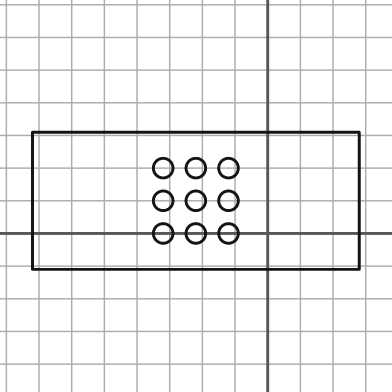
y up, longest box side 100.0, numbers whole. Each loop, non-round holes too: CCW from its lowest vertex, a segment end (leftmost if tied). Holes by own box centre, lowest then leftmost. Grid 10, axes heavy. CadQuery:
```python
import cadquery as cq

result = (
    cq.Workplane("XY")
    .moveTo(-72.0, -11.0)
    .lineTo(28.0, -11.0)
    .lineTo(28.0, 31.0)
    .lineTo(-72.0, 31.0)
    .close()
    .moveTo(-32.0, 0.0)
    .circle(3.0)
    .moveTo(-22.0, 0.0)
    .circle(3.0)
    .moveTo(-12.0, 0.0)
    .circle(3.0)
    .moveTo(-32.0, 10.0)
    .circle(3.0)
    .moveTo(-22.0, 10.0)
    .circle(3.0)
    .moveTo(-12.0, 10.0)
    .circle(3.0)
    .moveTo(-32.0, 20.0)
    .circle(3.0)
    .moveTo(-22.0, 20.0)
    .circle(3.0)
    .moveTo(-12.0, 20.0)
    .circle(3.0)
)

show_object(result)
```